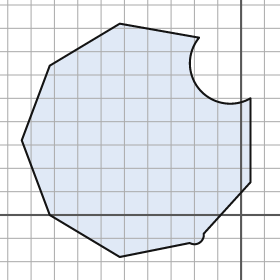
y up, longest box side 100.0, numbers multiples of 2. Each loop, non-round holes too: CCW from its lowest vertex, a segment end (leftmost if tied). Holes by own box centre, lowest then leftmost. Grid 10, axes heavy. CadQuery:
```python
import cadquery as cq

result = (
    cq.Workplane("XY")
    .moveTo(-52.0, -18.0)
    .lineTo(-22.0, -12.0)
    .threePointArc((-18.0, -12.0), (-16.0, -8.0))
    .lineTo(4.0, 14.0)
    .lineTo(4.0, 50.0)
    .threePointArc((-18.0, 54.0), (-18.0, 76.0))
    .lineTo(-52.0, 82.0)
    .lineTo(-82.0, 64.0)
    .lineTo(-94.0, 32.0)
    .lineTo(-82.0, 0.0)
    .close()
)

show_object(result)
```